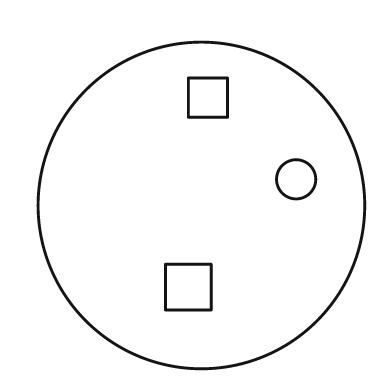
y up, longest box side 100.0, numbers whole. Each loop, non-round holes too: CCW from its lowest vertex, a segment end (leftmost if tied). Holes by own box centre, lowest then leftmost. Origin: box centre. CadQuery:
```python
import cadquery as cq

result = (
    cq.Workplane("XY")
    .moveTo(0.0, 0.0)
    .circle(50.0)
    .moveTo(-11.0, -32.0)
    .lineTo(3.0, -32.0)
    .lineTo(3.0, -18.0)
    .lineTo(-11.0, -18.0)
    .close()
    .moveTo(29.0, 8.0)
    .circle(6.0)
    .moveTo(-4.0, 27.0)
    .lineTo(8.0, 27.0)
    .lineTo(8.0, 39.0)
    .lineTo(-4.0, 39.0)
    .close()
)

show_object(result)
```